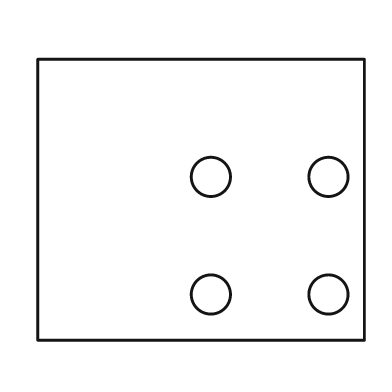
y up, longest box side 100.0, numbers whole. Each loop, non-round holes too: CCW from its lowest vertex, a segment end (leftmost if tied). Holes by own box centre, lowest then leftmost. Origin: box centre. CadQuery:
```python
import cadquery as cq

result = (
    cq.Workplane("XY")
    .moveTo(-50.0, -43.0)
    .lineTo(50.0, -43.0)
    .lineTo(50.0, 43.0)
    .lineTo(-50.0, 43.0)
    .close()
    .moveTo(3.0, -29.0)
    .circle(6.0)
    .moveTo(39.0, -29.0)
    .circle(6.0)
    .moveTo(3.0, 7.0)
    .circle(6.0)
    .moveTo(39.0, 7.0)
    .circle(6.0)
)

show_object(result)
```